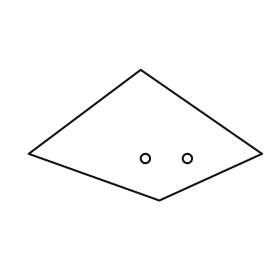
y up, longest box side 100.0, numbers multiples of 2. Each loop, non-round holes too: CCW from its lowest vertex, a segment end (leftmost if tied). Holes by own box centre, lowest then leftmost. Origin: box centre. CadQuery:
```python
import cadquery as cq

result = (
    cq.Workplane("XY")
    .moveTo(6.0, -28.0)
    .lineTo(50.0, -8.0)
    .lineTo(-2.0, 28.0)
    .lineTo(-50.0, -8.0)
    .close()
    .moveTo(0.0, -10.0)
    .circle(2.0)
    .moveTo(18.0, -10.0)
    .circle(2.0)
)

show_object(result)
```